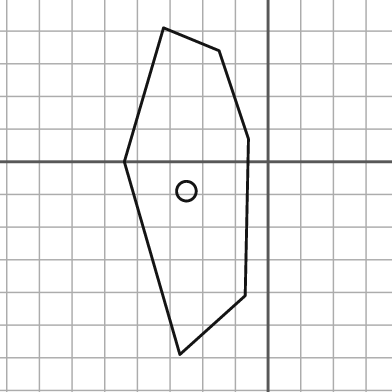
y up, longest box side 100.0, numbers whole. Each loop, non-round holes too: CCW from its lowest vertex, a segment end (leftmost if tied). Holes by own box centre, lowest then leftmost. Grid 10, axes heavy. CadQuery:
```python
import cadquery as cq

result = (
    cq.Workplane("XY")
    .moveTo(-27.0, -59.0)
    .lineTo(-7.0, -41.0)
    .lineTo(-6.0, 7.0)
    .lineTo(-15.0, 34.0)
    .lineTo(-32.0, 41.0)
    .lineTo(-44.0, 0.0)
    .close()
    .moveTo(-25.0, -9.0)
    .circle(3.0)
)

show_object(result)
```